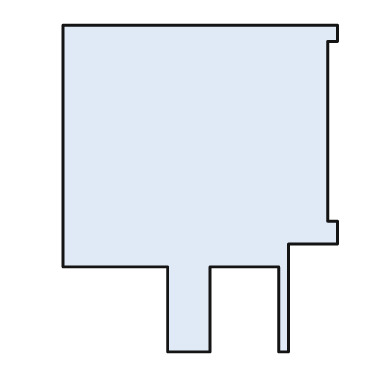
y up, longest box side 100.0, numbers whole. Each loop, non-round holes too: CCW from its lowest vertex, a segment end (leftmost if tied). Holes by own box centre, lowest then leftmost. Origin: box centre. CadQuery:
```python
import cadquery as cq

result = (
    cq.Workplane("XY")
    .moveTo(-10.0, -50.0)
    .lineTo(3.0, -50.0)
    .lineTo(3.0, -24.0)
    .lineTo(24.0, -24.0)
    .lineTo(24.0, -50.0)
    .lineTo(27.0, -50.0)
    .lineTo(27.0, -17.0)
    .lineTo(42.0, -17.0)
    .lineTo(42.0, -10.0)
    .lineTo(39.0, -10.0)
    .lineTo(39.0, 45.0)
    .lineTo(42.0, 45.0)
    .lineTo(42.0, 50.0)
    .lineTo(-42.0, 50.0)
    .lineTo(-42.0, -24.0)
    .lineTo(-10.0, -24.0)
    .close()
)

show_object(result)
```